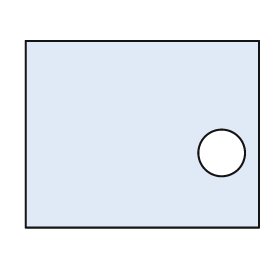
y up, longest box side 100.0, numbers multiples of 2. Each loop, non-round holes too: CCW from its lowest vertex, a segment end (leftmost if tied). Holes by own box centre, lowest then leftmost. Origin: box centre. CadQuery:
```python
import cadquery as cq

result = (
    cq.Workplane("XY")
    .moveTo(-50.0, -40.0)
    .lineTo(50.0, -40.0)
    .lineTo(50.0, 40.0)
    .lineTo(-50.0, 40.0)
    .close()
    .moveTo(34.0, -8.0)
    .circle(10.0)
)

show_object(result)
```